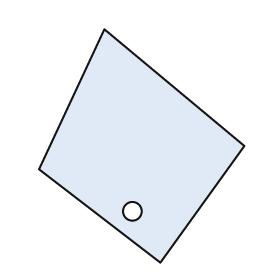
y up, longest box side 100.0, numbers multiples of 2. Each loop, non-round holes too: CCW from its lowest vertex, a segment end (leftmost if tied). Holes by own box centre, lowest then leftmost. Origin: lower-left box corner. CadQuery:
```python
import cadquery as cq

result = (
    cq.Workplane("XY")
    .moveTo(52.0, 0.0)
    .lineTo(88.0, 50.0)
    .lineTo(28.0, 100.0)
    .lineTo(0.0, 40.0)
    .close()
    .moveTo(40.0, 22.0)
    .circle(4.0)
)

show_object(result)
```